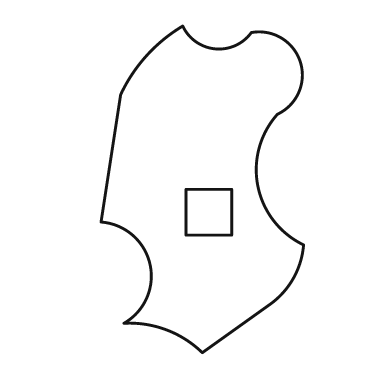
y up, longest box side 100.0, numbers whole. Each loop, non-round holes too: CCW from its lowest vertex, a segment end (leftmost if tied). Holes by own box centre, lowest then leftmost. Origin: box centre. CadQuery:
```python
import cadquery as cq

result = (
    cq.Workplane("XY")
    .moveTo(0.0, -50.0)
    .lineTo(21.0, -35.0)
    .threePointArc((28.0, -27.0), (31.0, -17.0))
    .threePointArc((17.0, 1.0), (23.0, 23.0))
    .threePointArc((30.0, 39.0), (15.0, 48.0))
    .threePointArc((4.0, 43.0), (-6.0, 50.0))
    .threePointArc((-17.0, 41.0), (-25.0, 29.0))
    .lineTo(-31.0, -10.0)
    .threePointArc((-16.0, -23.0), (-24.0, -41.0))
    .threePointArc((-11.0, -43.0), (0.0, -50.0))
    .close()
    .moveTo(-5.0, -14.0)
    .lineTo(9.0, -14.0)
    .lineTo(9.0, 0.0)
    .lineTo(-5.0, 0.0)
    .close()
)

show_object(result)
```